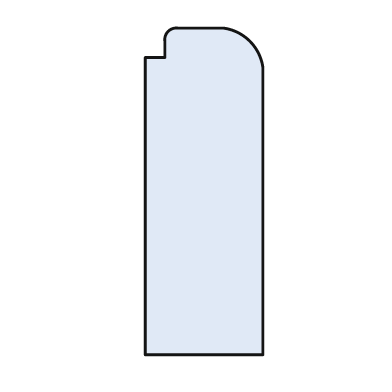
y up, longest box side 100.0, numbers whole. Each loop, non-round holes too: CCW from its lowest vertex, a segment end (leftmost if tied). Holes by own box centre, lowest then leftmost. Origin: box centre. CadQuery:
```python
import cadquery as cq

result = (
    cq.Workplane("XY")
    .moveTo(-18.0, -50.0)
    .lineTo(18.0, -50.0)
    .lineTo(18.0, 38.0)
    .threePointArc((14.0, 46.0), (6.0, 50.0))
    .lineTo(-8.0, 50.0)
    .threePointArc((-11.0, 49.0), (-12.0, 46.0))
    .lineTo(-12.0, 41.0)
    .lineTo(-18.0, 41.0)
    .close()
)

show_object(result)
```